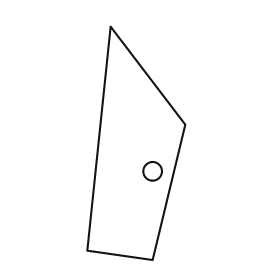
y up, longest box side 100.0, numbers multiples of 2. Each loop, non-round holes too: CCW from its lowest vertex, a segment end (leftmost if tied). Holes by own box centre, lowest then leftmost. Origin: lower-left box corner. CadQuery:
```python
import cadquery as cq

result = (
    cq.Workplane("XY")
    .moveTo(28.0, 0.0)
    .lineTo(42.0, 58.0)
    .lineTo(10.0, 100.0)
    .lineTo(0.0, 4.0)
    .close()
    .moveTo(28.0, 38.0)
    .circle(4.0)
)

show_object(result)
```